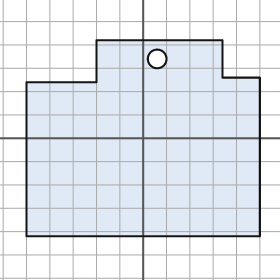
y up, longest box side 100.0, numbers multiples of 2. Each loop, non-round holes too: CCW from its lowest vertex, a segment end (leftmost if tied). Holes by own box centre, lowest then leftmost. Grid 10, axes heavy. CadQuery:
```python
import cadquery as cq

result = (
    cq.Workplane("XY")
    .moveTo(-50.0, -42.0)
    .lineTo(50.0, -42.0)
    .lineTo(50.0, 26.0)
    .lineTo(34.0, 26.0)
    .lineTo(34.0, 42.0)
    .lineTo(-20.0, 42.0)
    .lineTo(-20.0, 24.0)
    .lineTo(-50.0, 24.0)
    .close()
    .moveTo(6.0, 34.0)
    .circle(4.0)
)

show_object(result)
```